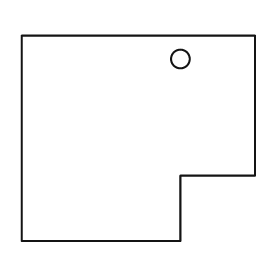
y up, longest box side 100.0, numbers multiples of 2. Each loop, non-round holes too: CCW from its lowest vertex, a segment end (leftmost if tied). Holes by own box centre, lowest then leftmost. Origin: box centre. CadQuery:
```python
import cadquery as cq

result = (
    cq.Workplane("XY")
    .moveTo(-50.0, -44.0)
    .lineTo(18.0, -44.0)
    .lineTo(18.0, -16.0)
    .lineTo(50.0, -16.0)
    .lineTo(50.0, 44.0)
    .lineTo(-50.0, 44.0)
    .close()
    .moveTo(18.0, 34.0)
    .circle(4.0)
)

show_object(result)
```